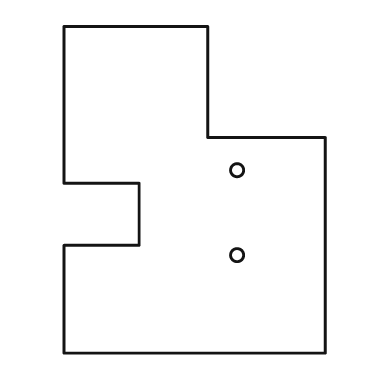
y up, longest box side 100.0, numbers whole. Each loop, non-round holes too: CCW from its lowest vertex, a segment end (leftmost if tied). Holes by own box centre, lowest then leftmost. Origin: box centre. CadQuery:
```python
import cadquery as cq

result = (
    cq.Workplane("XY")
    .moveTo(-40.0, -50.0)
    .lineTo(40.0, -50.0)
    .lineTo(40.0, 16.0)
    .lineTo(4.0, 16.0)
    .lineTo(4.0, 50.0)
    .lineTo(-40.0, 50.0)
    .lineTo(-40.0, 2.0)
    .lineTo(-17.0, 2.0)
    .lineTo(-17.0, -17.0)
    .lineTo(-40.0, -17.0)
    .close()
    .moveTo(13.0, -20.0)
    .circle(2.0)
    .moveTo(13.0, 6.0)
    .circle(2.0)
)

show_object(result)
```